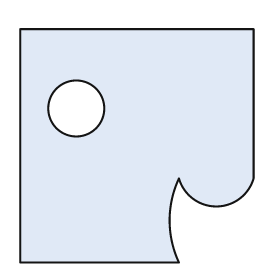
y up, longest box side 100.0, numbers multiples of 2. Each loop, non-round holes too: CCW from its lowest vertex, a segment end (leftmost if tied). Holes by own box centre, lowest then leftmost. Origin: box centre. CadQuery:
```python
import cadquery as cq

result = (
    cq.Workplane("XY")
    .moveTo(-50.0, -50.0)
    .lineTo(18.0, -50.0)
    .threePointArc((14.0, -32.0), (18.0, -14.0))
    .threePointArc((34.0, -26.0), (50.0, -14.0))
    .lineTo(50.0, 50.0)
    .lineTo(-50.0, 50.0)
    .close()
    .moveTo(-26.0, 16.0)
    .circle(12.0)
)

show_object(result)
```